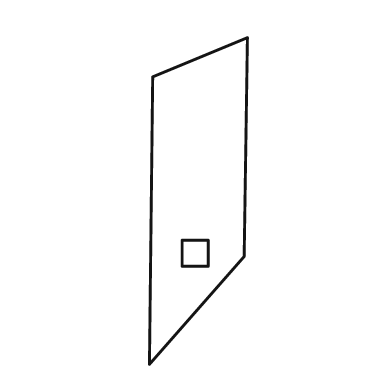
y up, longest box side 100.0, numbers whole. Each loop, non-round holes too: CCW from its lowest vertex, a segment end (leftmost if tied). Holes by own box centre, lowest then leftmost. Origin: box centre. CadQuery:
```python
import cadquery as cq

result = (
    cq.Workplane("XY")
    .moveTo(-15.0, -50.0)
    .lineTo(14.0, -17.0)
    .lineTo(15.0, 50.0)
    .lineTo(-14.0, 38.0)
    .close()
    .moveTo(-5.0, -20.0)
    .lineTo(3.0, -20.0)
    .lineTo(3.0, -12.0)
    .lineTo(-5.0, -12.0)
    .close()
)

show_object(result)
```